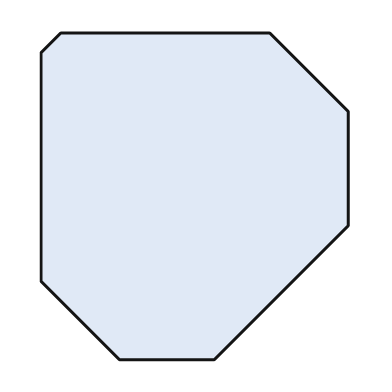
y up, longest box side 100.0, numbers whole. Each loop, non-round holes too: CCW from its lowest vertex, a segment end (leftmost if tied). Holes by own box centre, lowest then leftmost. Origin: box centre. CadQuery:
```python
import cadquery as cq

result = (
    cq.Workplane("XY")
    .moveTo(-23.0, -50.0)
    .lineTo(6.0, -50.0)
    .lineTo(47.0, -9.0)
    .lineTo(47.0, 26.0)
    .lineTo(23.0, 50.0)
    .lineTo(-41.0, 50.0)
    .lineTo(-47.0, 44.0)
    .lineTo(-47.0, -26.0)
    .close()
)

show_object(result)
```